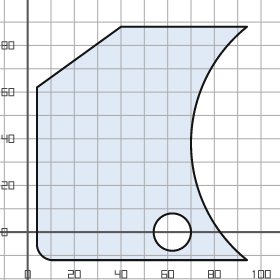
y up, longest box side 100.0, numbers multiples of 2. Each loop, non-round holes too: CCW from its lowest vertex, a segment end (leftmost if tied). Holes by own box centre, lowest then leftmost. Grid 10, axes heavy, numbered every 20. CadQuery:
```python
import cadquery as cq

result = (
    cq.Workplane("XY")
    .moveTo(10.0, -12.0)
    .lineTo(94.0, -12.0)
    .threePointArc((70.0, 38.0), (94.0, 88.0))
    .lineTo(40.0, 88.0)
    .lineTo(4.0, 62.0)
    .lineTo(4.0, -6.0)
    .threePointArc((6.0, -10.0), (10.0, -12.0))
    .close()
    .moveTo(62.0, 0.0)
    .circle(8.0)
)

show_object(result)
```